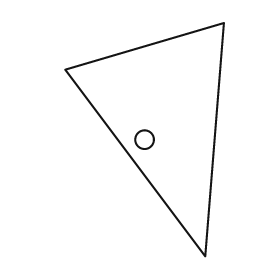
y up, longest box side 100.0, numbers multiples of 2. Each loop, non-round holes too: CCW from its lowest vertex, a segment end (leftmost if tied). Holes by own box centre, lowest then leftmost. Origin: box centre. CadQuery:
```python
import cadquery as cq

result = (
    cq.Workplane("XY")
    .moveTo(26.0, -50.0)
    .lineTo(34.0, 50.0)
    .lineTo(-34.0, 30.0)
    .close()
    .moveTo(0.0, 0.0)
    .circle(4.0)
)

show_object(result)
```